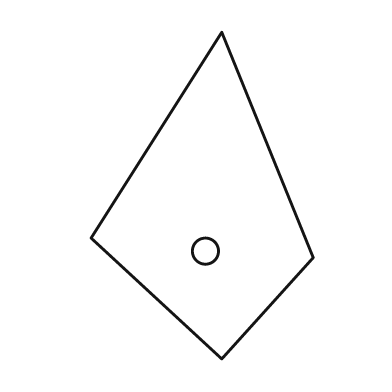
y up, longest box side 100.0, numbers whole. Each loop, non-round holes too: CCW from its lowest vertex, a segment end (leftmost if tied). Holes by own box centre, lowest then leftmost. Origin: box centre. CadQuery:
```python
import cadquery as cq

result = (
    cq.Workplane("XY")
    .moveTo(6.0, -50.0)
    .lineTo(34.0, -19.0)
    .lineTo(6.0, 50.0)
    .lineTo(-34.0, -13.0)
    .close()
    .moveTo(1.0, -17.0)
    .circle(4.0)
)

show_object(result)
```